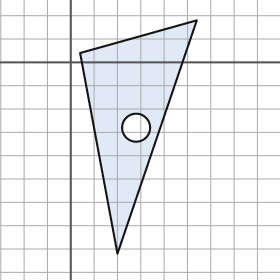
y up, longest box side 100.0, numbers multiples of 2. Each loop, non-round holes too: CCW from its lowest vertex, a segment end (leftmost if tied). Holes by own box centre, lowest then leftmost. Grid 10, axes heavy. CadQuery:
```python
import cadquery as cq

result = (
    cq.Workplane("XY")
    .moveTo(20.0, -82.0)
    .lineTo(54.0, 18.0)
    .lineTo(4.0, 4.0)
    .close()
    .moveTo(28.0, -28.0)
    .circle(6.0)
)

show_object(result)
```